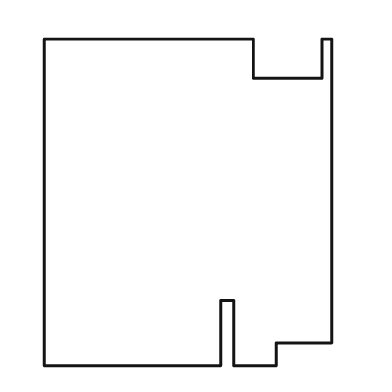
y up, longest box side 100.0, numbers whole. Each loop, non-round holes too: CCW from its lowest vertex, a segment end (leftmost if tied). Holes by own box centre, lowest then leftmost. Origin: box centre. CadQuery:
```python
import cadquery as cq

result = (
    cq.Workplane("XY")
    .moveTo(-44.0, -50.0)
    .lineTo(10.0, -50.0)
    .lineTo(10.0, -30.0)
    .lineTo(14.0, -30.0)
    .lineTo(14.0, -50.0)
    .lineTo(27.0, -50.0)
    .lineTo(27.0, -43.0)
    .lineTo(44.0, -43.0)
    .lineTo(44.0, 50.0)
    .lineTo(41.0, 50.0)
    .lineTo(41.0, 38.0)
    .lineTo(20.0, 38.0)
    .lineTo(20.0, 50.0)
    .lineTo(-44.0, 50.0)
    .close()
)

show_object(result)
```